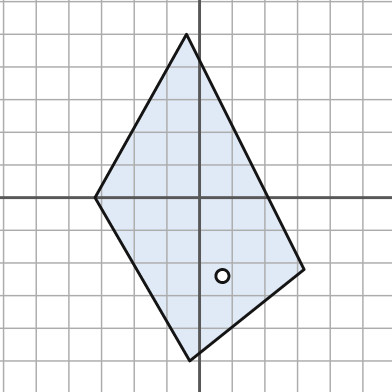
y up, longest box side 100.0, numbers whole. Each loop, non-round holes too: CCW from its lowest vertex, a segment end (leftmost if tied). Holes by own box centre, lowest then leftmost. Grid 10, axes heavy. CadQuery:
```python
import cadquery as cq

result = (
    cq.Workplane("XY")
    .moveTo(-3.0, -50.0)
    .lineTo(32.0, -22.0)
    .lineTo(-4.0, 50.0)
    .lineTo(-32.0, 0.0)
    .close()
    .moveTo(7.0, -24.0)
    .circle(2.0)
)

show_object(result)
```